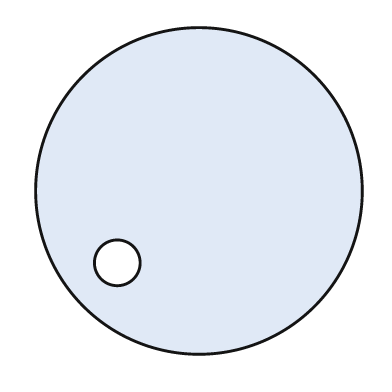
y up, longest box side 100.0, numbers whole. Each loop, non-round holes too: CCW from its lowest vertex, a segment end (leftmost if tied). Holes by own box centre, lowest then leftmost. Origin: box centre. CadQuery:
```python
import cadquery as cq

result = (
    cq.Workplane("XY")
    .moveTo(0.0, 0.0)
    .circle(50.0)
    .moveTo(-25.0, -22.0)
    .circle(7.0)
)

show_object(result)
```